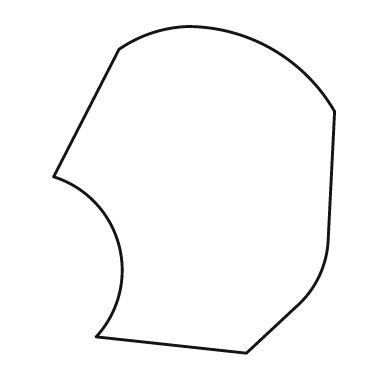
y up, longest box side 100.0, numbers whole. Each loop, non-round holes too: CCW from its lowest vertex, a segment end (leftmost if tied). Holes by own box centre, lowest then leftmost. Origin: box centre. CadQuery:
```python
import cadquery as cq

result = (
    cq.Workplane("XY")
    .moveTo(16.0, -50.0)
    .lineTo(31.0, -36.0)
    .threePointArc((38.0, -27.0), (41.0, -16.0))
    .lineTo(43.0, 24.0)
    .threePointArc((24.0, 43.0), (-2.0, 50.0))
    .threePointArc((-13.0, 48.0), (-23.0, 43.0))
    .lineTo(-43.0, 4.0)
    .threePointArc((-23.0, -17.0), (-30.0, -45.0))
    .close()
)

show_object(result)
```